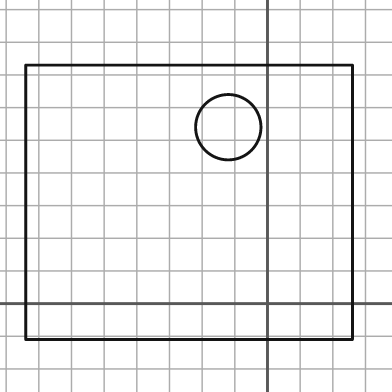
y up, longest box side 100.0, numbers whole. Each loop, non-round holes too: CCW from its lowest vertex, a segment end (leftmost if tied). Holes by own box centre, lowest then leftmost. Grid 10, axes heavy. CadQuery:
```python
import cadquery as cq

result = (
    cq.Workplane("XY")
    .moveTo(-74.0, -11.0)
    .lineTo(26.0, -11.0)
    .lineTo(26.0, 73.0)
    .lineTo(-74.0, 73.0)
    .close()
    .moveTo(-12.0, 54.0)
    .circle(10.0)
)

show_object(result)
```